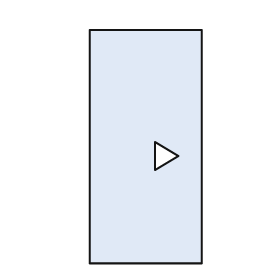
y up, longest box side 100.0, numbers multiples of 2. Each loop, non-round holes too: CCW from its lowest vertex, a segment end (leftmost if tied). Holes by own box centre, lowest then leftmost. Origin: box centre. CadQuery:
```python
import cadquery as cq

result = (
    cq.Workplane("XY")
    .moveTo(-24.0, -50.0)
    .lineTo(24.0, -50.0)
    .lineTo(24.0, 50.0)
    .lineTo(-24.0, 50.0)
    .close()
    .moveTo(4.0, -10.0)
    .lineTo(14.0, -4.0)
    .lineTo(4.0, 2.0)
    .close()
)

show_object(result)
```